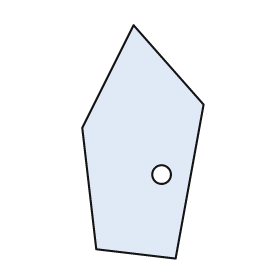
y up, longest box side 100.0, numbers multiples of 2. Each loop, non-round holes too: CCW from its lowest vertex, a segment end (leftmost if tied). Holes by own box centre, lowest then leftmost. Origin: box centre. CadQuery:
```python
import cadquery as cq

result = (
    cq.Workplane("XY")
    .moveTo(14.0, -50.0)
    .lineTo(26.0, 16.0)
    .lineTo(-4.0, 50.0)
    .lineTo(-26.0, 6.0)
    .lineTo(-20.0, -46.0)
    .close()
    .moveTo(8.0, -14.0)
    .circle(4.0)
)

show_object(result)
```